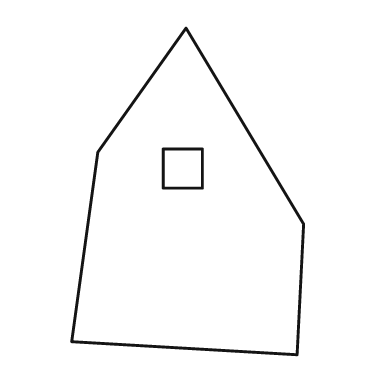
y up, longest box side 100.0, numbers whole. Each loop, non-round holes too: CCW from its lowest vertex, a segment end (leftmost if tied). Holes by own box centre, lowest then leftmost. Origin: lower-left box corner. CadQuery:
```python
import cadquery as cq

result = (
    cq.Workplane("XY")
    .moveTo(69.0, 0.0)
    .lineTo(71.0, 40.0)
    .lineTo(35.0, 100.0)
    .lineTo(8.0, 62.0)
    .lineTo(0.0, 4.0)
    .close()
    .moveTo(28.0, 51.0)
    .lineTo(40.0, 51.0)
    .lineTo(40.0, 63.0)
    .lineTo(28.0, 63.0)
    .close()
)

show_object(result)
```